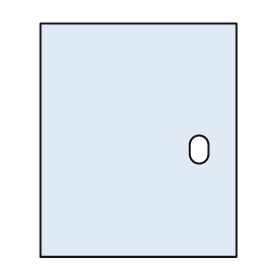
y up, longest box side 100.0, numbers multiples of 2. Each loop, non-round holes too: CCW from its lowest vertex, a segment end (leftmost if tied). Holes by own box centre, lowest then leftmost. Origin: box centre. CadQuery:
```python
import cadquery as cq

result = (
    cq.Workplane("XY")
    .moveTo(-42.0, -50.0)
    .lineTo(42.0, -50.0)
    .lineTo(42.0, 50.0)
    .lineTo(-42.0, 50.0)
    .close()
    .moveTo(22.0, -6.0)
    .threePointArc((26.0, -10.0), (30.0, -6.0))
    .lineTo(30.0, -2.0)
    .threePointArc((26.0, 2.0), (22.0, -2.0))
    .close()
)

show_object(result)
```